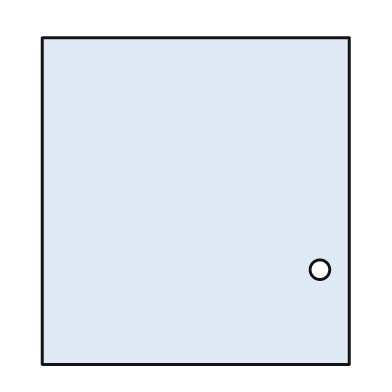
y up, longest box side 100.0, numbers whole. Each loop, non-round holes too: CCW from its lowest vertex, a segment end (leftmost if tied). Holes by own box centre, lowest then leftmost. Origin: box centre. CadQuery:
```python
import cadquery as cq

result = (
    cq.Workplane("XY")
    .moveTo(-47.0, -50.0)
    .lineTo(47.0, -50.0)
    .lineTo(47.0, 50.0)
    .lineTo(-47.0, 50.0)
    .close()
    .moveTo(38.0, -21.0)
    .circle(3.0)
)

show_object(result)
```